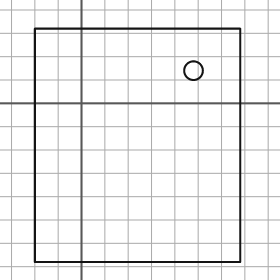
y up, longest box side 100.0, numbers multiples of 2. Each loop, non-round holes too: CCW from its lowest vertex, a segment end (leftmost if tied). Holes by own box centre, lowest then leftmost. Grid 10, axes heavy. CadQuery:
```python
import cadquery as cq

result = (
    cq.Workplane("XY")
    .moveTo(-20.0, -68.0)
    .lineTo(68.0, -68.0)
    .lineTo(68.0, 32.0)
    .lineTo(-20.0, 32.0)
    .close()
    .moveTo(48.0, 14.0)
    .circle(4.0)
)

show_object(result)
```